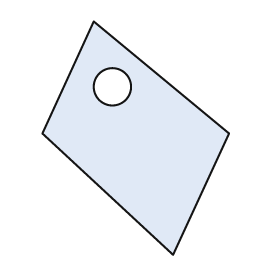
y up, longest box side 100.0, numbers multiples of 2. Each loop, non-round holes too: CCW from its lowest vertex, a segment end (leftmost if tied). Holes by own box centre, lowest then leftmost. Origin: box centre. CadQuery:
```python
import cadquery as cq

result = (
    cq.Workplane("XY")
    .moveTo(16.0, -50.0)
    .lineTo(40.0, 2.0)
    .lineTo(-18.0, 50.0)
    .lineTo(-40.0, 2.0)
    .close()
    .moveTo(-10.0, 22.0)
    .circle(8.0)
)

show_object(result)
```